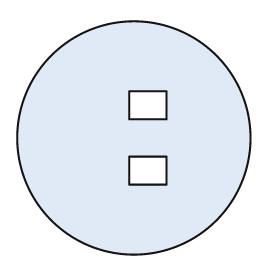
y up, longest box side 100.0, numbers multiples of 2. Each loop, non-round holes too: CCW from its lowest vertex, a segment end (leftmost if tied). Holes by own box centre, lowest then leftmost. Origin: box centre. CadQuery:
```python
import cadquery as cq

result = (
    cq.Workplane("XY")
    .moveTo(0.0, 0.0)
    .circle(50.0)
    .moveTo(-2.0, -20.0)
    .lineTo(14.0, -20.0)
    .lineTo(14.0, -8.0)
    .lineTo(-2.0, -8.0)
    .close()
    .moveTo(-2.0, 8.0)
    .lineTo(14.0, 8.0)
    .lineTo(14.0, 20.0)
    .lineTo(-2.0, 20.0)
    .close()
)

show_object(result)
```